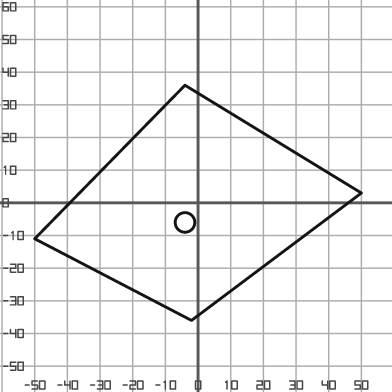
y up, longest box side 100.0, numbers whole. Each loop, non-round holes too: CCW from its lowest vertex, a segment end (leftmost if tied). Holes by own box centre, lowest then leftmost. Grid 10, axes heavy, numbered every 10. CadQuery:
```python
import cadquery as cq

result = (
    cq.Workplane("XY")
    .moveTo(-2.0, -36.0)
    .lineTo(50.0, 3.0)
    .lineTo(-4.0, 36.0)
    .lineTo(-50.0, -11.0)
    .close()
    .moveTo(-4.0, -6.0)
    .circle(3.0)
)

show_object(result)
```